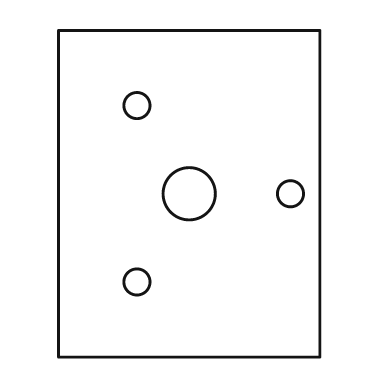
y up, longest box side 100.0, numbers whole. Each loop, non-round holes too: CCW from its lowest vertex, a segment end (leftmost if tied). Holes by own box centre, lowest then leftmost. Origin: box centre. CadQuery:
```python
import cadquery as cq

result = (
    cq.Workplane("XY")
    .moveTo(-40.0, -50.0)
    .lineTo(40.0, -50.0)
    .lineTo(40.0, 50.0)
    .lineTo(-40.0, 50.0)
    .close()
    .moveTo(-16.0, -27.0)
    .circle(4.0)
    .moveTo(0.0, 0.0)
    .circle(8.0)
    .moveTo(31.0, 0.0)
    .circle(4.0)
    .moveTo(-16.0, 27.0)
    .circle(4.0)
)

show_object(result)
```